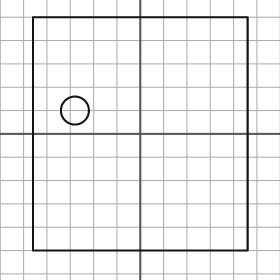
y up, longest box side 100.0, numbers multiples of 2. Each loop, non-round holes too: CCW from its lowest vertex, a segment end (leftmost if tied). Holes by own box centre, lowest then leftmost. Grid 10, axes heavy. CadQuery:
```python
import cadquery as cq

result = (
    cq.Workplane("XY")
    .moveTo(-46.0, -50.0)
    .lineTo(46.0, -50.0)
    .lineTo(46.0, 50.0)
    .lineTo(-46.0, 50.0)
    .close()
    .moveTo(-28.0, 10.0)
    .circle(6.0)
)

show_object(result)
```